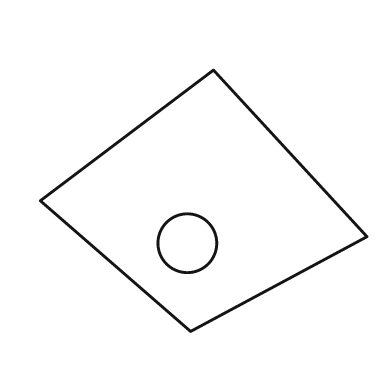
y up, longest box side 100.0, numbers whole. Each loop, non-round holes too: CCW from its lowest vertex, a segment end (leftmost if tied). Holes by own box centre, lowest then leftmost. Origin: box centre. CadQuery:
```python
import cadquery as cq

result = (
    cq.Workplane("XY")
    .moveTo(-4.0, -40.0)
    .lineTo(50.0, -11.0)
    .lineTo(3.0, 40.0)
    .lineTo(-50.0, 0.0)
    .close()
    .moveTo(-5.0, -13.0)
    .circle(9.0)
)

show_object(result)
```